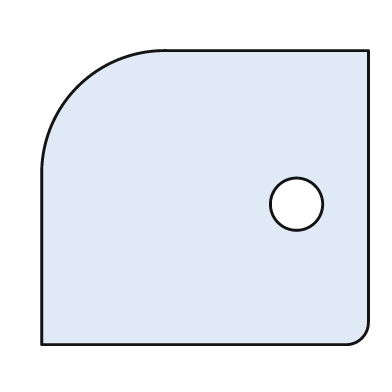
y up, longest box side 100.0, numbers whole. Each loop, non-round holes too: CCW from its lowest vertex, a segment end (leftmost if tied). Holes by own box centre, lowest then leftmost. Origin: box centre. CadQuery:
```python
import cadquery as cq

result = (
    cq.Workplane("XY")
    .moveTo(-50.0, -45.0)
    .lineTo(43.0, -45.0)
    .threePointArc((48.0, -43.0), (50.0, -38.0))
    .lineTo(50.0, 45.0)
    .lineTo(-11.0, 45.0)
    .threePointArc((-39.0, 34.0), (-50.0, 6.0))
    .close()
    .moveTo(28.0, -2.0)
    .circle(8.0)
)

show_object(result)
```